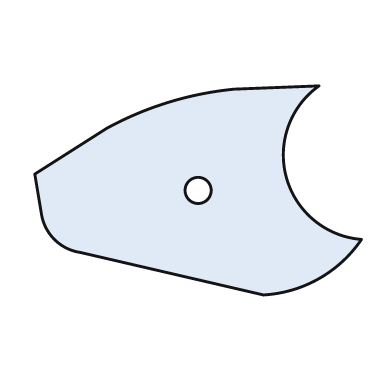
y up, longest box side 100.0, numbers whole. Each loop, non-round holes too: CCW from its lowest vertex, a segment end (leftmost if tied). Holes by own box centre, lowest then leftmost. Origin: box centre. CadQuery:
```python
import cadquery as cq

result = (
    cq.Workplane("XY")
    .moveTo(20.0, -32.0)
    .threePointArc((37.0, -27.0), (50.0, -15.0))
    .threePointArc((27.0, 4.0), (37.0, 32.0))
    .lineTo(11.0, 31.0)
    .threePointArc((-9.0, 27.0), (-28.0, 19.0))
    .lineTo(-50.0, 5.0)
    .lineTo(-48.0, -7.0)
    .threePointArc((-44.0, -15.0), (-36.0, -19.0))
    .close()
    .moveTo(0.0, 0.0)
    .circle(4.0)
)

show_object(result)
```